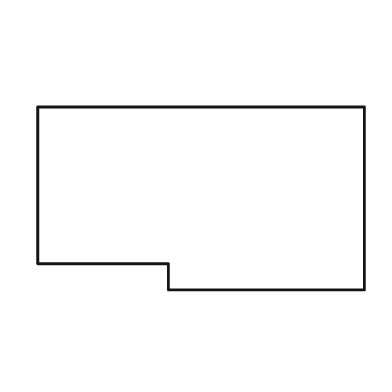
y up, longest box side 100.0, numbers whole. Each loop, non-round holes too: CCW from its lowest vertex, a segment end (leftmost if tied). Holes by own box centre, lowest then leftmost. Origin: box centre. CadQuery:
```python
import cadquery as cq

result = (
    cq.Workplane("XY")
    .moveTo(-10.0, -28.0)
    .lineTo(50.0, -28.0)
    .lineTo(50.0, 28.0)
    .lineTo(-50.0, 28.0)
    .lineTo(-50.0, -20.0)
    .lineTo(-10.0, -20.0)
    .close()
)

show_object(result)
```